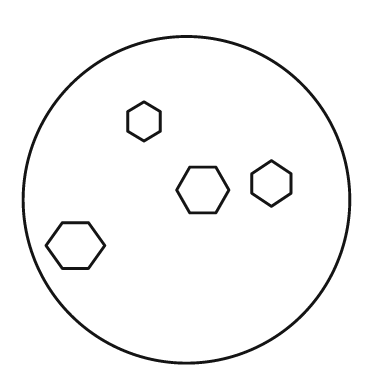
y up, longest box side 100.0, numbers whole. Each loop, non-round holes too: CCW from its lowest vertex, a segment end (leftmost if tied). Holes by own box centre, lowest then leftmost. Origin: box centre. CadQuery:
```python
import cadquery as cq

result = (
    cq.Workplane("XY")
    .moveTo(0.0, 0.0)
    .circle(50.0)
    .moveTo(-38.0, -21.0)
    .lineTo(-30.0, -21.0)
    .lineTo(-25.0, -14.0)
    .lineTo(-30.0, -7.0)
    .lineTo(-38.0, -7.0)
    .lineTo(-43.0, -14.0)
    .close()
    .moveTo(1.0, -4.0)
    .lineTo(9.0, -4.0)
    .lineTo(13.0, 3.0)
    .lineTo(9.0, 10.0)
    .lineTo(1.0, 10.0)
    .lineTo(-3.0, 3.0)
    .close()
    .moveTo(26.0, -2.0)
    .lineTo(32.0, 2.0)
    .lineTo(32.0, 8.0)
    .lineTo(26.0, 12.0)
    .lineTo(20.0, 8.0)
    .lineTo(20.0, 2.0)
    .close()
    .moveTo(-13.0, 18.0)
    .lineTo(-8.0, 21.0)
    .lineTo(-8.0, 27.0)
    .lineTo(-13.0, 30.0)
    .lineTo(-18.0, 27.0)
    .lineTo(-18.0, 21.0)
    .close()
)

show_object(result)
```